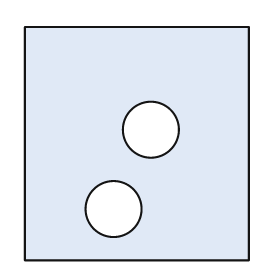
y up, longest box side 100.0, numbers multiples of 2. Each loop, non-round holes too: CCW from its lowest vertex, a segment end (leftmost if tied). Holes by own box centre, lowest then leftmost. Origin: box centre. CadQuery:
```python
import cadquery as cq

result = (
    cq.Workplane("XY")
    .moveTo(-48.0, -50.0)
    .lineTo(48.0, -50.0)
    .lineTo(48.0, 50.0)
    .lineTo(-48.0, 50.0)
    .close()
    .moveTo(-10.0, -28.0)
    .circle(12.0)
    .moveTo(6.0, 6.0)
    .circle(12.0)
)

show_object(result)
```